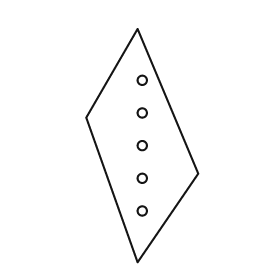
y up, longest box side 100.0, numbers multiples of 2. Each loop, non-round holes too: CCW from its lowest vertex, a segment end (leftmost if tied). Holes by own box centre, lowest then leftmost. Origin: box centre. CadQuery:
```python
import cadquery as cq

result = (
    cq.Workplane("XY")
    .moveTo(-2.0, -50.0)
    .lineTo(24.0, -12.0)
    .lineTo(-2.0, 50.0)
    .lineTo(-24.0, 12.0)
    .close()
    .moveTo(0.0, -28.0)
    .circle(2.0)
    .moveTo(0.0, -14.0)
    .circle(2.0)
    .moveTo(0.0, 0.0)
    .circle(2.0)
    .moveTo(0.0, 14.0)
    .circle(2.0)
    .moveTo(0.0, 28.0)
    .circle(2.0)
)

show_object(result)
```